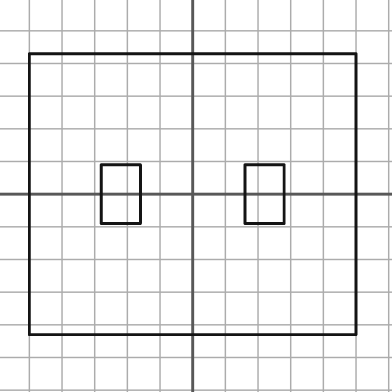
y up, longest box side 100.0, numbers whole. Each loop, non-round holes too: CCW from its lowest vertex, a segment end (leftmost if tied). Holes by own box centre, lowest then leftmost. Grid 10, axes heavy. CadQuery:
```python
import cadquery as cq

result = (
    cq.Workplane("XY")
    .moveTo(-50.0, -43.0)
    .lineTo(50.0, -43.0)
    .lineTo(50.0, 43.0)
    .lineTo(-50.0, 43.0)
    .close()
    .moveTo(-28.0, -9.0)
    .lineTo(-16.0, -9.0)
    .lineTo(-16.0, 9.0)
    .lineTo(-28.0, 9.0)
    .close()
    .moveTo(16.0, -9.0)
    .lineTo(28.0, -9.0)
    .lineTo(28.0, 9.0)
    .lineTo(16.0, 9.0)
    .close()
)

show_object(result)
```